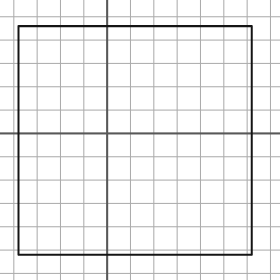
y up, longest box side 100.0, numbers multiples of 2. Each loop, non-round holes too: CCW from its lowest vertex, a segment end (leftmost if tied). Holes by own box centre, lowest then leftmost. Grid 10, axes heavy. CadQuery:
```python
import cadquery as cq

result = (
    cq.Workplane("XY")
    .moveTo(-38.0, -52.0)
    .lineTo(62.0, -52.0)
    .lineTo(62.0, 46.0)
    .lineTo(-38.0, 46.0)
    .close()
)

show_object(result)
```